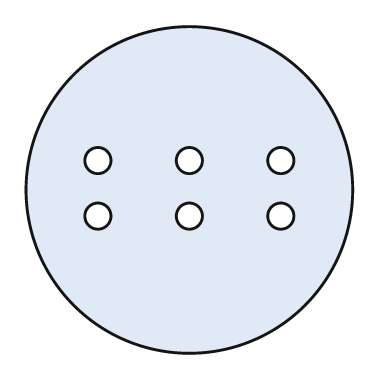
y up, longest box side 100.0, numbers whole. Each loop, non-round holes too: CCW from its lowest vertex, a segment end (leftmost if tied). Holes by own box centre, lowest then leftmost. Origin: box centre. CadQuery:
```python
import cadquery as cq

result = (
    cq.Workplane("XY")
    .moveTo(0.0, 0.0)
    .circle(50.0)
    .moveTo(-28.0, -8.0)
    .circle(4.0)
    .moveTo(0.0, -8.0)
    .circle(4.0)
    .moveTo(28.0, -8.0)
    .circle(4.0)
    .moveTo(-28.0, 9.0)
    .circle(4.0)
    .moveTo(0.0, 9.0)
    .circle(4.0)
    .moveTo(28.0, 9.0)
    .circle(4.0)
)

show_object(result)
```